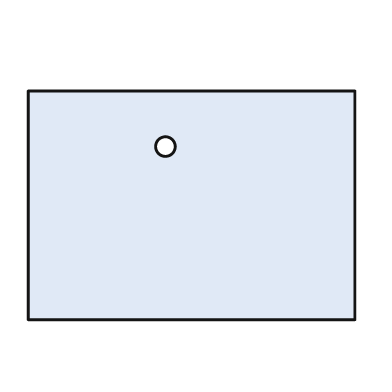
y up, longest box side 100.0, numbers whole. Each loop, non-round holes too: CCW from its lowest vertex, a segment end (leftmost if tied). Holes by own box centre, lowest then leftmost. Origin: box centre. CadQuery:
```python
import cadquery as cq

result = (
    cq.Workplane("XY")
    .moveTo(-50.0, -35.0)
    .lineTo(50.0, -35.0)
    .lineTo(50.0, 35.0)
    .lineTo(-50.0, 35.0)
    .close()
    .moveTo(-8.0, 18.0)
    .circle(3.0)
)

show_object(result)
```